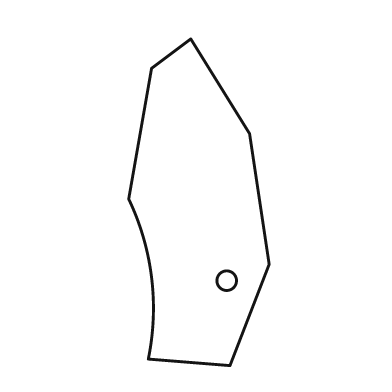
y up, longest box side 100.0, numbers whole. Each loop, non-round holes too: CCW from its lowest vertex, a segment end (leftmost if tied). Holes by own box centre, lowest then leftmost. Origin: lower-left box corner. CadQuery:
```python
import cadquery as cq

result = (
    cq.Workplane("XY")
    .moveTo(31.0, 0.0)
    .lineTo(43.0, 31.0)
    .lineTo(37.0, 71.0)
    .lineTo(19.0, 100.0)
    .lineTo(7.0, 91.0)
    .lineTo(0.0, 51.0)
    .threePointArc((7.0, 27.0), (6.0, 2.0))
    .close()
    .moveTo(30.0, 26.0)
    .circle(3.0)
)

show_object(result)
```